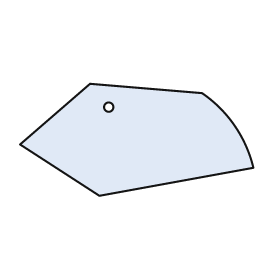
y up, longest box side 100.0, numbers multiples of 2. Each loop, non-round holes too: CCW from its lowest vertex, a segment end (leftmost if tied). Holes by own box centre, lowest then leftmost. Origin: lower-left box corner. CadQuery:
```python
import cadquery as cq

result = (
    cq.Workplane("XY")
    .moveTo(34.0, 0.0)
    .lineTo(100.0, 12.0)
    .threePointArc((92.0, 30.0), (78.0, 44.0))
    .lineTo(30.0, 48.0)
    .lineTo(0.0, 22.0)
    .close()
    .moveTo(38.0, 38.0)
    .circle(2.0)
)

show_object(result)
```